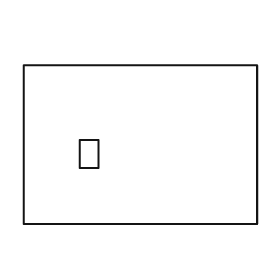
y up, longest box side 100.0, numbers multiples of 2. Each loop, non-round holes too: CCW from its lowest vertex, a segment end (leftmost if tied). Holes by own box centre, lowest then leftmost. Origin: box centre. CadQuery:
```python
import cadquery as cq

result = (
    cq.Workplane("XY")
    .moveTo(-50.0, -34.0)
    .lineTo(50.0, -34.0)
    .lineTo(50.0, 34.0)
    .lineTo(-50.0, 34.0)
    .close()
    .moveTo(-26.0, -10.0)
    .lineTo(-18.0, -10.0)
    .lineTo(-18.0, 2.0)
    .lineTo(-26.0, 2.0)
    .close()
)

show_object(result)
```